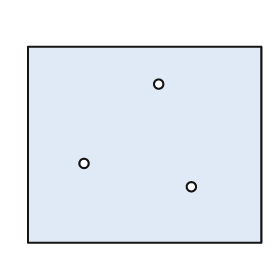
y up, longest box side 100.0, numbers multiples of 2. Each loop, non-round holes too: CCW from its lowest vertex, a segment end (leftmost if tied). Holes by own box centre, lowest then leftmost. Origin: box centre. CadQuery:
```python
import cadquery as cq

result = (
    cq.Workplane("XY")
    .moveTo(-50.0, -42.0)
    .lineTo(50.0, -42.0)
    .lineTo(50.0, 42.0)
    .lineTo(-50.0, 42.0)
    .close()
    .moveTo(20.0, -18.0)
    .circle(2.0)
    .moveTo(-26.0, -8.0)
    .circle(2.0)
    .moveTo(6.0, 26.0)
    .circle(2.0)
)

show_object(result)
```